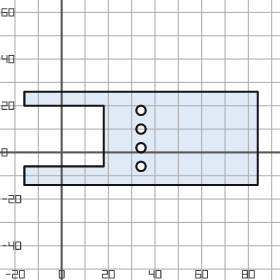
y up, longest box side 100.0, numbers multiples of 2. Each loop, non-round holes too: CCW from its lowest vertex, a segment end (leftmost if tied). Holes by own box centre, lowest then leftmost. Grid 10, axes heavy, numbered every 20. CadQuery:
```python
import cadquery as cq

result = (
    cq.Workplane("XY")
    .moveTo(-16.0, -14.0)
    .lineTo(84.0, -14.0)
    .lineTo(84.0, 26.0)
    .lineTo(-16.0, 26.0)
    .lineTo(-16.0, 20.0)
    .lineTo(18.0, 20.0)
    .lineTo(18.0, -6.0)
    .lineTo(-16.0, -6.0)
    .close()
    .moveTo(34.0, -6.0)
    .circle(2.0)
    .moveTo(34.0, 2.0)
    .circle(2.0)
    .moveTo(34.0, 10.0)
    .circle(2.0)
    .moveTo(34.0, 18.0)
    .circle(2.0)
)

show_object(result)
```